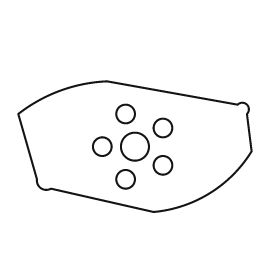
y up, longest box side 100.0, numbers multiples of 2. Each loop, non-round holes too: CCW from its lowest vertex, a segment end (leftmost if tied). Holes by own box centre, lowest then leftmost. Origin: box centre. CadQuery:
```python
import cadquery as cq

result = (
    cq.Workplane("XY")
    .moveTo(8.0, -28.0)
    .threePointArc((32.0, -20.0), (50.0, -2.0))
    .lineTo(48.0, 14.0)
    .threePointArc((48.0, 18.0), (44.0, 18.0))
    .lineTo(-12.0, 28.0)
    .threePointArc((-32.0, 24.0), (-50.0, 14.0))
    .lineTo(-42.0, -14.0)
    .threePointArc((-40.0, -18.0), (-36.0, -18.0))
    .close()
    .moveTo(-4.0, -14.0)
    .circle(4.0)
    .moveTo(12.0, -8.0)
    .circle(4.0)
    .moveTo(-14.0, 0.0)
    .circle(4.0)
    .moveTo(0.0, 0.0)
    .circle(6.0)
    .moveTo(12.0, 8.0)
    .circle(4.0)
    .moveTo(-4.0, 14.0)
    .circle(4.0)
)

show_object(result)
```